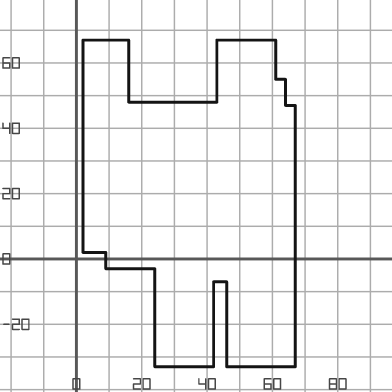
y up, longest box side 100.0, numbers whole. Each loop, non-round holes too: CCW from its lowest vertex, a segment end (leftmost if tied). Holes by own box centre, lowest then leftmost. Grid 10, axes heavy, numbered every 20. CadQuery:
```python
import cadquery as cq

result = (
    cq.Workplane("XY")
    .moveTo(24.0, -33.0)
    .lineTo(42.0, -33.0)
    .lineTo(42.0, -7.0)
    .lineTo(46.0, -7.0)
    .lineTo(46.0, -33.0)
    .lineTo(67.0, -33.0)
    .lineTo(67.0, 47.0)
    .lineTo(64.0, 47.0)
    .lineTo(64.0, 55.0)
    .lineTo(61.0, 55.0)
    .lineTo(61.0, 67.0)
    .lineTo(43.0, 67.0)
    .lineTo(43.0, 48.0)
    .lineTo(16.0, 48.0)
    .lineTo(16.0, 67.0)
    .lineTo(2.0, 67.0)
    .lineTo(2.0, 2.0)
    .lineTo(9.0, 2.0)
    .lineTo(9.0, -3.0)
    .lineTo(24.0, -3.0)
    .close()
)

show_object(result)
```